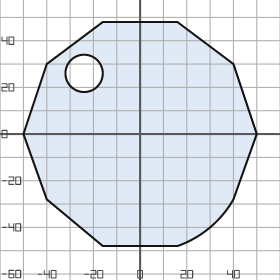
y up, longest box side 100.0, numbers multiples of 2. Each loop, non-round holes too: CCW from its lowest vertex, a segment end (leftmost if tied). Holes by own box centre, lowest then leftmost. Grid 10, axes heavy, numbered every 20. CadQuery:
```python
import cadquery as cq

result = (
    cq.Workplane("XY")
    .moveTo(-16.0, -48.0)
    .lineTo(16.0, -48.0)
    .threePointArc((30.0, -40.0), (40.0, -28.0))
    .lineTo(50.0, 0.0)
    .lineTo(40.0, 30.0)
    .lineTo(16.0, 48.0)
    .lineTo(-16.0, 48.0)
    .lineTo(-40.0, 30.0)
    .lineTo(-50.0, 0.0)
    .lineTo(-40.0, -28.0)
    .close()
    .moveTo(-24.0, 26.0)
    .circle(8.0)
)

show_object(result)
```